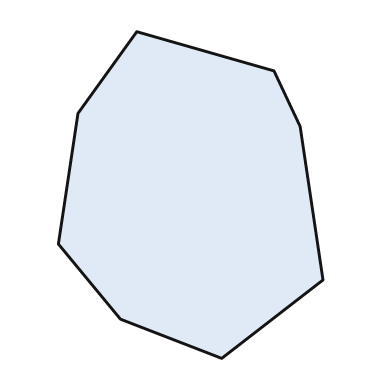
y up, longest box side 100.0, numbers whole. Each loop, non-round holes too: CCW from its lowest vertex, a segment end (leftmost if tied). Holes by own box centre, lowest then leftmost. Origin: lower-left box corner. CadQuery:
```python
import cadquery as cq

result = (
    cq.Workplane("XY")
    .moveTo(50.0, 0.0)
    .lineTo(81.0, 24.0)
    .lineTo(74.0, 71.0)
    .lineTo(66.0, 88.0)
    .lineTo(24.0, 100.0)
    .lineTo(6.0, 75.0)
    .lineTo(0.0, 35.0)
    .lineTo(19.0, 12.0)
    .close()
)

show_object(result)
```